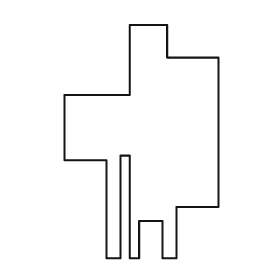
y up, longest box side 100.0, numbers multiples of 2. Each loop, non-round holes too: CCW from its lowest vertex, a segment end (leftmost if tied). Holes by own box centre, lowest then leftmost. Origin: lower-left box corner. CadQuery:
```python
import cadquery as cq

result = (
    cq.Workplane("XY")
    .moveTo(18.0, 0.0)
    .lineTo(24.0, 0.0)
    .lineTo(24.0, 44.0)
    .lineTo(28.0, 44.0)
    .lineTo(28.0, 0.0)
    .lineTo(32.0, 0.0)
    .lineTo(32.0, 16.0)
    .lineTo(42.0, 16.0)
    .lineTo(42.0, 0.0)
    .lineTo(48.0, 0.0)
    .lineTo(48.0, 22.0)
    .lineTo(66.0, 22.0)
    .lineTo(66.0, 86.0)
    .lineTo(44.0, 86.0)
    .lineTo(44.0, 100.0)
    .lineTo(28.0, 100.0)
    .lineTo(28.0, 70.0)
    .lineTo(0.0, 70.0)
    .lineTo(0.0, 42.0)
    .lineTo(18.0, 42.0)
    .close()
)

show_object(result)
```